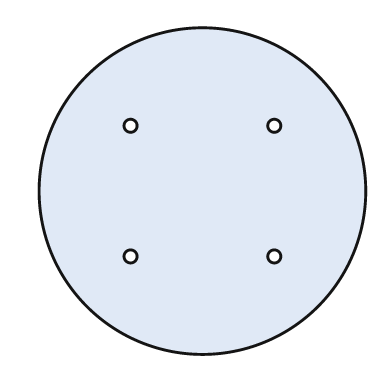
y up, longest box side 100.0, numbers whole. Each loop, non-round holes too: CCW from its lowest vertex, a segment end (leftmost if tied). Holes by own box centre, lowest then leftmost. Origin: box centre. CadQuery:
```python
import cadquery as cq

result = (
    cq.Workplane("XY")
    .moveTo(0.0, 0.0)
    .circle(50.0)
    .moveTo(-22.0, -20.0)
    .circle(2.0)
    .moveTo(22.0, -20.0)
    .circle(2.0)
    .moveTo(-22.0, 20.0)
    .circle(2.0)
    .moveTo(22.0, 20.0)
    .circle(2.0)
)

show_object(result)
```